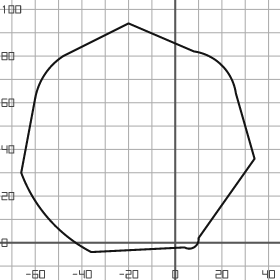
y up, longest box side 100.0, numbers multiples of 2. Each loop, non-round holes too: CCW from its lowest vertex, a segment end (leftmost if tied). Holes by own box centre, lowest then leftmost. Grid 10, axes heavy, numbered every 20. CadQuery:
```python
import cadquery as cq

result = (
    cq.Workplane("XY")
    .moveTo(-36.0, -4.0)
    .lineTo(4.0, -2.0)
    .threePointArc((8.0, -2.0), (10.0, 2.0))
    .lineTo(34.0, 36.0)
    .lineTo(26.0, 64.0)
    .threePointArc((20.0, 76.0), (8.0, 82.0))
    .lineTo(-20.0, 94.0)
    .lineTo(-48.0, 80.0)
    .threePointArc((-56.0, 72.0), (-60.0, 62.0))
    .lineTo(-66.0, 30.0)
    .threePointArc((-54.0, 10.0), (-36.0, -4.0))
    .close()
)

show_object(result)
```